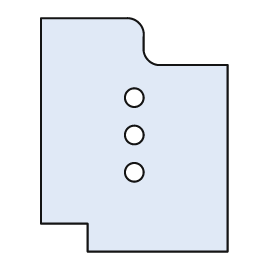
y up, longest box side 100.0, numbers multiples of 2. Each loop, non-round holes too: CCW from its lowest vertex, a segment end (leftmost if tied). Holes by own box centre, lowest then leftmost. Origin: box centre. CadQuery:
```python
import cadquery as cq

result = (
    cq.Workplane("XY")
    .moveTo(-20.0, -50.0)
    .lineTo(40.0, -50.0)
    .lineTo(40.0, 30.0)
    .lineTo(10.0, 30.0)
    .threePointArc((6.0, 32.0), (4.0, 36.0))
    .lineTo(4.0, 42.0)
    .threePointArc((2.0, 48.0), (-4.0, 50.0))
    .lineTo(-40.0, 50.0)
    .lineTo(-40.0, -38.0)
    .lineTo(-20.0, -38.0)
    .close()
    .moveTo(0.0, -16.0)
    .circle(4.0)
    .moveTo(0.0, 0.0)
    .circle(4.0)
    .moveTo(0.0, 16.0)
    .circle(4.0)
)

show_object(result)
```